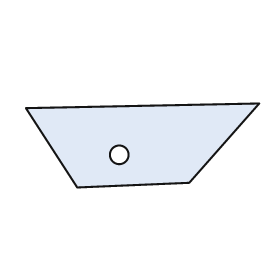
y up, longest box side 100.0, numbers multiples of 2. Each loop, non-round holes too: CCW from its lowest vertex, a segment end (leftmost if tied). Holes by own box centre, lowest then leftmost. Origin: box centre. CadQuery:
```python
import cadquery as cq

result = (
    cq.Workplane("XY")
    .moveTo(-28.0, -18.0)
    .lineTo(20.0, -16.0)
    .lineTo(50.0, 18.0)
    .lineTo(-50.0, 16.0)
    .close()
    .moveTo(-10.0, -4.0)
    .circle(4.0)
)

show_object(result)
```